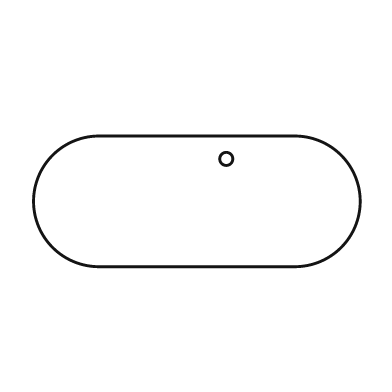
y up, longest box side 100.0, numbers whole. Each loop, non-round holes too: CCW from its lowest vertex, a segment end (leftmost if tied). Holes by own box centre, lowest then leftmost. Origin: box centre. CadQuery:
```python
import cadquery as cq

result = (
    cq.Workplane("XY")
    .moveTo(-30.0, -20.0)
    .lineTo(30.0, -20.0)
    .threePointArc((50.0, 0.0), (30.0, 20.0))
    .lineTo(-30.0, 20.0)
    .threePointArc((-50.0, 0.0), (-30.0, -20.0))
    .close()
    .moveTo(9.0, 13.0)
    .circle(2.0)
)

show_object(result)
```